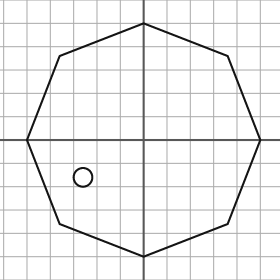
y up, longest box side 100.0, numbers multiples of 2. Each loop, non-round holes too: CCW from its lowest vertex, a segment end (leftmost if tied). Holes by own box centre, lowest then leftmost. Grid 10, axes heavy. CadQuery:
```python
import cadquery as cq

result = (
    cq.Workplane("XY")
    .moveTo(0.0, -50.0)
    .lineTo(36.0, -36.0)
    .lineTo(50.0, 0.0)
    .lineTo(36.0, 36.0)
    .lineTo(0.0, 50.0)
    .lineTo(-36.0, 36.0)
    .lineTo(-50.0, 0.0)
    .lineTo(-36.0, -36.0)
    .close()
    .moveTo(-26.0, -16.0)
    .circle(4.0)
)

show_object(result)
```